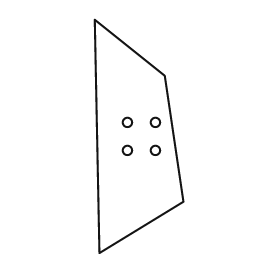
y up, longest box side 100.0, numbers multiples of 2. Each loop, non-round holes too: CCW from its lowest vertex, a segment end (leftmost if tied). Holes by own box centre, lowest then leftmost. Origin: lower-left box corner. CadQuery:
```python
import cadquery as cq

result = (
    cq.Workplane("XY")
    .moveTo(2.0, 0.0)
    .lineTo(38.0, 22.0)
    .lineTo(30.0, 76.0)
    .lineTo(0.0, 100.0)
    .close()
    .moveTo(14.0, 44.0)
    .circle(2.0)
    .moveTo(26.0, 44.0)
    .circle(2.0)
    .moveTo(14.0, 56.0)
    .circle(2.0)
    .moveTo(26.0, 56.0)
    .circle(2.0)
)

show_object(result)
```